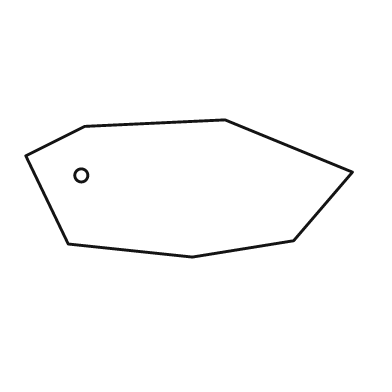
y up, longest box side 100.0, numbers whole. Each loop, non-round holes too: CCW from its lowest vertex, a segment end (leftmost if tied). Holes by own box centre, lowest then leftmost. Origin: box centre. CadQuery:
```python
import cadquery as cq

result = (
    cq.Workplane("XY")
    .moveTo(1.0, -21.0)
    .lineTo(32.0, -16.0)
    .lineTo(50.0, 5.0)
    .lineTo(11.0, 21.0)
    .lineTo(-32.0, 19.0)
    .lineTo(-50.0, 10.0)
    .lineTo(-37.0, -17.0)
    .close()
    .moveTo(-33.0, 4.0)
    .circle(2.0)
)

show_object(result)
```